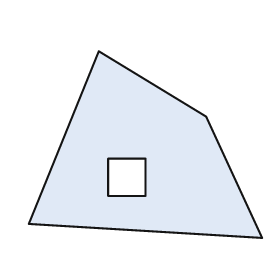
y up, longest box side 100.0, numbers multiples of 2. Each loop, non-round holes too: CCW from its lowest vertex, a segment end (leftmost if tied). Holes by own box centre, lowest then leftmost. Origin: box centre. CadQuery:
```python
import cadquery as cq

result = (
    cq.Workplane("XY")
    .moveTo(50.0, -40.0)
    .lineTo(26.0, 12.0)
    .lineTo(-20.0, 40.0)
    .lineTo(-50.0, -34.0)
    .close()
    .moveTo(-16.0, -22.0)
    .lineTo(0.0, -22.0)
    .lineTo(0.0, -6.0)
    .lineTo(-16.0, -6.0)
    .close()
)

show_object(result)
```